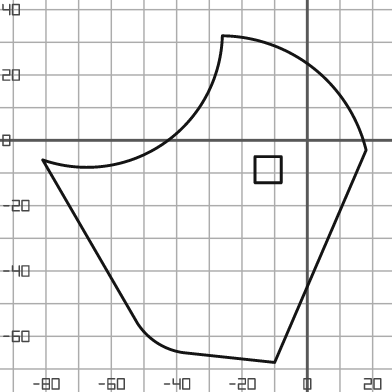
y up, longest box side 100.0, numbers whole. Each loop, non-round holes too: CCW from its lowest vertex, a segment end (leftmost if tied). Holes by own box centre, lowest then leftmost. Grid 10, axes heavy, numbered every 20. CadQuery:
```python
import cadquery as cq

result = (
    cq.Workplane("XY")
    .moveTo(-10.0, -68.0)
    .lineTo(18.0, -3.0)
    .threePointArc((2.0, 22.0), (-26.0, 32.0))
    .threePointArc((-44.0, -1.0), (-81.0, -6.0))
    .lineTo(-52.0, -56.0)
    .threePointArc((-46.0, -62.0), (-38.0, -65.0))
    .close()
    .moveTo(-16.0, -13.0)
    .lineTo(-8.0, -13.0)
    .lineTo(-8.0, -5.0)
    .lineTo(-16.0, -5.0)
    .close()
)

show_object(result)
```